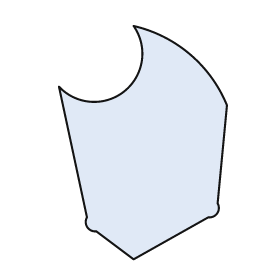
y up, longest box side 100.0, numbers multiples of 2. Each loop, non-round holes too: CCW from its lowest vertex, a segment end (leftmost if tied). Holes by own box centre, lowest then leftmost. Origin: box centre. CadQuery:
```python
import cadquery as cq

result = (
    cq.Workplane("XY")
    .moveTo(-4.0, -50.0)
    .lineTo(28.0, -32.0)
    .threePointArc((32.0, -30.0), (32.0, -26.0))
    .lineTo(36.0, 16.0)
    .threePointArc((20.0, 38.0), (-4.0, 50.0))
    .threePointArc((-8.0, 22.0), (-36.0, 24.0))
    .lineTo(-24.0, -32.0)
    .threePointArc((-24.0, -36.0), (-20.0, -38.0))
    .close()
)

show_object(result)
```